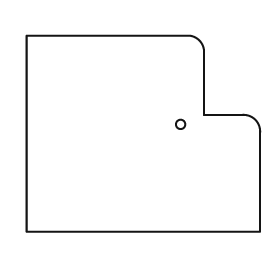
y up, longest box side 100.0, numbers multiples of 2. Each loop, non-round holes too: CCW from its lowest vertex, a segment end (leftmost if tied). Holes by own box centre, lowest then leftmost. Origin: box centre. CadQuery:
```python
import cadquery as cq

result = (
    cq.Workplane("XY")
    .moveTo(-50.0, -42.0)
    .lineTo(50.0, -42.0)
    .lineTo(50.0, 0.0)
    .threePointArc((48.0, 6.0), (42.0, 8.0))
    .lineTo(26.0, 8.0)
    .lineTo(26.0, 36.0)
    .threePointArc((24.0, 40.0), (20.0, 42.0))
    .lineTo(-50.0, 42.0)
    .close()
    .moveTo(16.0, 4.0)
    .circle(2.0)
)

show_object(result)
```